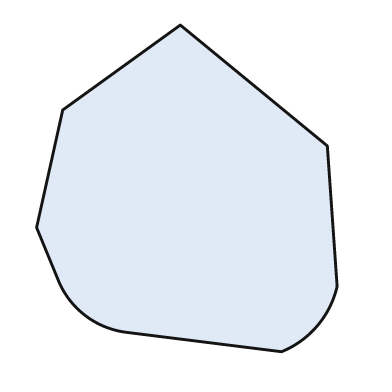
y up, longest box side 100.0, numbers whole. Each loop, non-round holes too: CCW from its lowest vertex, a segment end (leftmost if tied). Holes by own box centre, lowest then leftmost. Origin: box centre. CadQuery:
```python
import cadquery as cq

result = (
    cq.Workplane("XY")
    .moveTo(29.0, -50.0)
    .threePointArc((40.0, -42.0), (46.0, -30.0))
    .lineTo(43.0, 13.0)
    .lineTo(-2.0, 50.0)
    .lineTo(-38.0, 24.0)
    .lineTo(-46.0, -12.0)
    .lineTo(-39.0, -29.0)
    .threePointArc((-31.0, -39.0), (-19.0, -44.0))
    .close()
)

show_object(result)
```